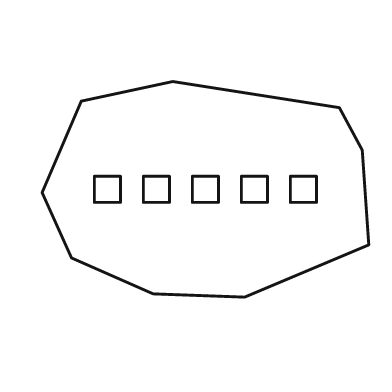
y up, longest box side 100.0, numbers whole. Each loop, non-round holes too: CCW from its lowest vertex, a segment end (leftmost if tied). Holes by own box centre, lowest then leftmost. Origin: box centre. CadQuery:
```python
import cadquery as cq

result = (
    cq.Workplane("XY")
    .moveTo(12.0, -33.0)
    .lineTo(50.0, -17.0)
    .lineTo(48.0, 12.0)
    .lineTo(41.0, 25.0)
    .lineTo(-10.0, 33.0)
    .lineTo(-38.0, 27.0)
    .lineTo(-50.0, -1.0)
    .lineTo(-41.0, -21.0)
    .lineTo(-16.0, -32.0)
    .close()
    .moveTo(-34.0, -4.0)
    .lineTo(-26.0, -4.0)
    .lineTo(-26.0, 4.0)
    .lineTo(-34.0, 4.0)
    .close()
    .moveTo(-19.0, -4.0)
    .lineTo(-11.0, -4.0)
    .lineTo(-11.0, 4.0)
    .lineTo(-19.0, 4.0)
    .close()
    .moveTo(-4.0, -4.0)
    .lineTo(4.0, -4.0)
    .lineTo(4.0, 4.0)
    .lineTo(-4.0, 4.0)
    .close()
    .moveTo(11.0, -4.0)
    .lineTo(19.0, -4.0)
    .lineTo(19.0, 4.0)
    .lineTo(11.0, 4.0)
    .close()
    .moveTo(26.0, -4.0)
    .lineTo(34.0, -4.0)
    .lineTo(34.0, 4.0)
    .lineTo(26.0, 4.0)
    .close()
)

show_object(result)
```